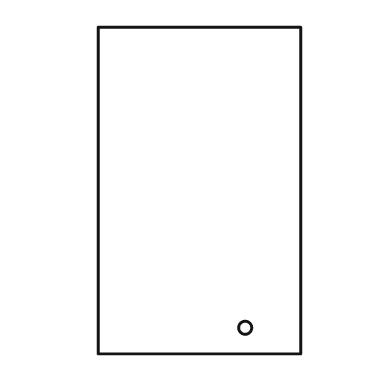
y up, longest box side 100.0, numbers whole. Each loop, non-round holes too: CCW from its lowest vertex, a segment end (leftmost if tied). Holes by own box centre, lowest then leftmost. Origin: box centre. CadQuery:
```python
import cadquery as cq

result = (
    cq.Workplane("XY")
    .moveTo(-31.0, -50.0)
    .lineTo(31.0, -50.0)
    .lineTo(31.0, 50.0)
    .lineTo(-31.0, 50.0)
    .close()
    .moveTo(14.0, -42.0)
    .circle(2.0)
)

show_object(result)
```